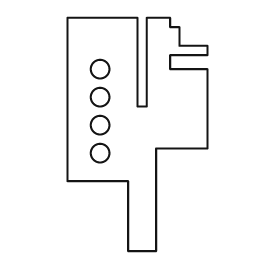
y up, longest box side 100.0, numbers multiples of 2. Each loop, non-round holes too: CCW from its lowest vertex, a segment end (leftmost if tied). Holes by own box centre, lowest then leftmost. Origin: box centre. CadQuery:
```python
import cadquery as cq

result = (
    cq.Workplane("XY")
    .moveTo(-4.0, -50.0)
    .lineTo(8.0, -50.0)
    .lineTo(8.0, -6.0)
    .lineTo(30.0, -6.0)
    .lineTo(30.0, 28.0)
    .lineTo(14.0, 28.0)
    .lineTo(14.0, 34.0)
    .lineTo(30.0, 34.0)
    .lineTo(30.0, 38.0)
    .lineTo(18.0, 38.0)
    .lineTo(18.0, 46.0)
    .lineTo(14.0, 46.0)
    .lineTo(14.0, 50.0)
    .lineTo(4.0, 50.0)
    .lineTo(4.0, 12.0)
    .lineTo(0.0, 12.0)
    .lineTo(0.0, 50.0)
    .lineTo(-30.0, 50.0)
    .lineTo(-30.0, -20.0)
    .lineTo(-4.0, -20.0)
    .close()
    .moveTo(-16.0, -8.0)
    .circle(4.0)
    .moveTo(-16.0, 4.0)
    .circle(4.0)
    .moveTo(-16.0, 16.0)
    .circle(4.0)
    .moveTo(-16.0, 28.0)
    .circle(4.0)
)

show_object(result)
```